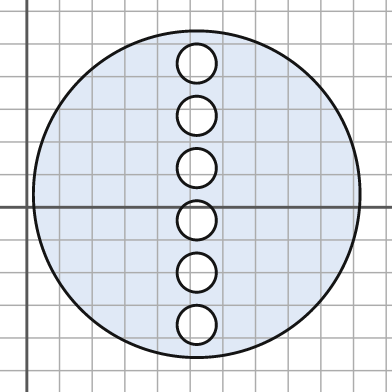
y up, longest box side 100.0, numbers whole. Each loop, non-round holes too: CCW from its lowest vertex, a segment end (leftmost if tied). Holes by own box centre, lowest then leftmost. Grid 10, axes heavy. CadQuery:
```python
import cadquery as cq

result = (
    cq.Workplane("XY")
    .moveTo(52.0, 4.0)
    .circle(50.0)
    .moveTo(52.0, -36.0)
    .circle(6.0)
    .moveTo(52.0, -20.0)
    .circle(6.0)
    .moveTo(52.0, -4.0)
    .circle(6.0)
    .moveTo(52.0, 12.0)
    .circle(6.0)
    .moveTo(52.0, 28.0)
    .circle(6.0)
    .moveTo(52.0, 44.0)
    .circle(6.0)
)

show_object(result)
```